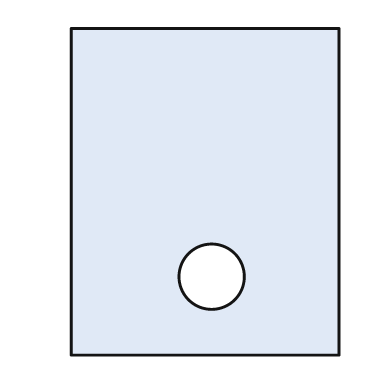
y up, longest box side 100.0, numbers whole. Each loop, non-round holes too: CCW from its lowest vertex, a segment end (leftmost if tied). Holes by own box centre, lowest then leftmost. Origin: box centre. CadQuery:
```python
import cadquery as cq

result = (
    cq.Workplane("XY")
    .moveTo(-41.0, -50.0)
    .lineTo(41.0, -50.0)
    .lineTo(41.0, 50.0)
    .lineTo(-41.0, 50.0)
    .close()
    .moveTo(2.0, -26.0)
    .circle(10.0)
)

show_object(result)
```